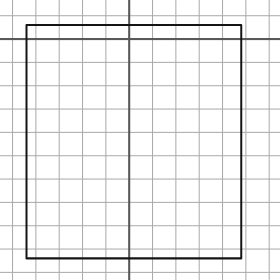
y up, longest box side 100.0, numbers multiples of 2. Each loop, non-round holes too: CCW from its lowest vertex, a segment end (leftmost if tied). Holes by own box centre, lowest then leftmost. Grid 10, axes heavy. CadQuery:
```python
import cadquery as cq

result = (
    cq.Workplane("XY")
    .moveTo(-44.0, -94.0)
    .lineTo(48.0, -94.0)
    .lineTo(48.0, 6.0)
    .lineTo(-44.0, 6.0)
    .close()
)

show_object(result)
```